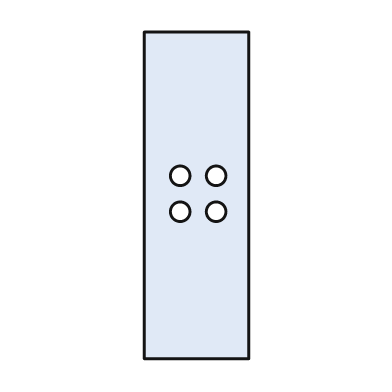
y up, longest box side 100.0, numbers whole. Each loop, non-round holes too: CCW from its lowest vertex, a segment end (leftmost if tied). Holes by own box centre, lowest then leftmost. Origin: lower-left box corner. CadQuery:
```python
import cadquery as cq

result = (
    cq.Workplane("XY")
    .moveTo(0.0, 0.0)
    .lineTo(32.0, 0.0)
    .lineTo(32.0, 100.0)
    .lineTo(0.0, 100.0)
    .close()
    .moveTo(11.0, 45.0)
    .circle(3.0)
    .moveTo(22.0, 45.0)
    .circle(3.0)
    .moveTo(11.0, 56.0)
    .circle(3.0)
    .moveTo(22.0, 56.0)
    .circle(3.0)
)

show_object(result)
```